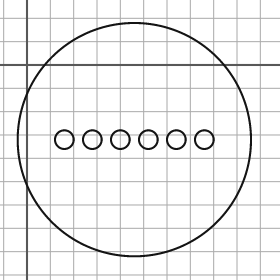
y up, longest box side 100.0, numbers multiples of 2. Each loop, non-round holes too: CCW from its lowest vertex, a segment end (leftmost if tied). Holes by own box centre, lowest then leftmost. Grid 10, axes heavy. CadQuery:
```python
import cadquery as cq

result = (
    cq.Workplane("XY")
    .moveTo(46.0, -32.0)
    .circle(50.0)
    .moveTo(16.0, -32.0)
    .circle(4.0)
    .moveTo(28.0, -32.0)
    .circle(4.0)
    .moveTo(40.0, -32.0)
    .circle(4.0)
    .moveTo(52.0, -32.0)
    .circle(4.0)
    .moveTo(64.0, -32.0)
    .circle(4.0)
    .moveTo(76.0, -32.0)
    .circle(4.0)
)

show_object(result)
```